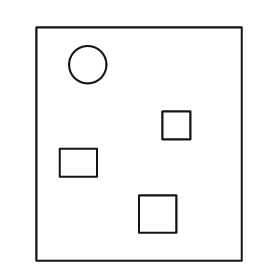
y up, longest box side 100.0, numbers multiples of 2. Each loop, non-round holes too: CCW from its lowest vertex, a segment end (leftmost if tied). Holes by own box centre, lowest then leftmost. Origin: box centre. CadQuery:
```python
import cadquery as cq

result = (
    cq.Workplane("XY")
    .moveTo(-44.0, -50.0)
    .lineTo(44.0, -50.0)
    .lineTo(44.0, 50.0)
    .lineTo(-44.0, 50.0)
    .close()
    .moveTo(0.0, -38.0)
    .lineTo(16.0, -38.0)
    .lineTo(16.0, -22.0)
    .lineTo(0.0, -22.0)
    .close()
    .moveTo(-34.0, -14.0)
    .lineTo(-18.0, -14.0)
    .lineTo(-18.0, -2.0)
    .lineTo(-34.0, -2.0)
    .close()
    .moveTo(10.0, 2.0)
    .lineTo(22.0, 2.0)
    .lineTo(22.0, 14.0)
    .lineTo(10.0, 14.0)
    .close()
    .moveTo(-22.0, 34.0)
    .circle(8.0)
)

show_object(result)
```